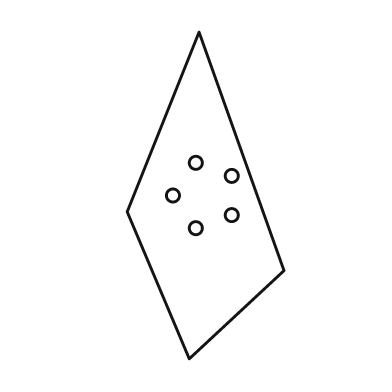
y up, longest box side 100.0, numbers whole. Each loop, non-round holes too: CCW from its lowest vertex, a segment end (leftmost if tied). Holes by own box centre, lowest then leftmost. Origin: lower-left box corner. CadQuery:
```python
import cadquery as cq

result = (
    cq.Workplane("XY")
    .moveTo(19.0, 0.0)
    .lineTo(48.0, 27.0)
    .lineTo(22.0, 100.0)
    .lineTo(0.0, 45.0)
    .close()
    .moveTo(21.0, 40.0)
    .circle(2.0)
    .moveTo(32.0, 44.0)
    .circle(2.0)
    .moveTo(14.0, 50.0)
    .circle(2.0)
    .moveTo(32.0, 56.0)
    .circle(2.0)
    .moveTo(21.0, 60.0)
    .circle(2.0)
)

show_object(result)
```